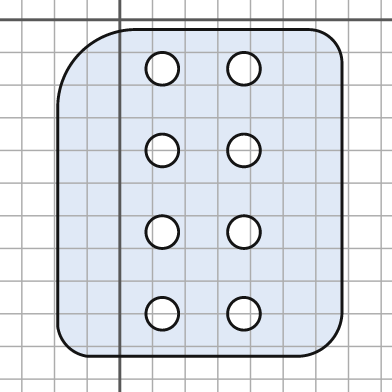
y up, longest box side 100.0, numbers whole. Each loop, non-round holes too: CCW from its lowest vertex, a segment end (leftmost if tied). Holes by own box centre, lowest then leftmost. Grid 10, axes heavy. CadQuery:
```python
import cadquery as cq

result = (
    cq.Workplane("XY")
    .moveTo(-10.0, -103.0)
    .lineTo(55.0, -103.0)
    .threePointArc((64.0, -99.0), (68.0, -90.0))
    .lineTo(68.0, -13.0)
    .threePointArc((65.0, -6.0), (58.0, -3.0))
    .lineTo(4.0, -3.0)
    .threePointArc((-12.0, -10.0), (-19.0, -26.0))
    .lineTo(-19.0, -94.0)
    .threePointArc((-16.0, -100.0), (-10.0, -103.0))
    .close()
    .moveTo(13.0, -90.0)
    .circle(5.0)
    .moveTo(38.0, -90.0)
    .circle(5.0)
    .moveTo(13.0, -65.0)
    .circle(5.0)
    .moveTo(38.0, -65.0)
    .circle(5.0)
    .moveTo(13.0, -40.0)
    .circle(5.0)
    .moveTo(38.0, -40.0)
    .circle(5.0)
    .moveTo(13.0, -15.0)
    .circle(5.0)
    .moveTo(38.0, -15.0)
    .circle(5.0)
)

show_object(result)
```